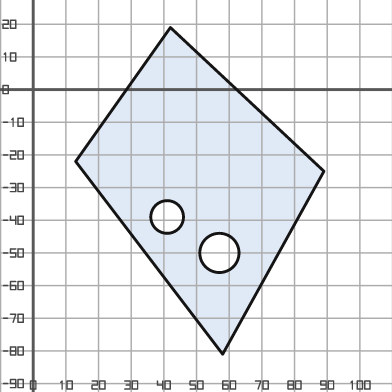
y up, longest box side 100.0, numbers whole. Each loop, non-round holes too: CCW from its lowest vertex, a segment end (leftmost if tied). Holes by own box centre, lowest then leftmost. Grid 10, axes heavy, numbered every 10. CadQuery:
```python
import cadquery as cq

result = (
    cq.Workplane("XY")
    .moveTo(58.0, -81.0)
    .lineTo(89.0, -25.0)
    .lineTo(42.0, 19.0)
    .lineTo(13.0, -22.0)
    .close()
    .moveTo(57.0, -50.0)
    .circle(6.0)
    .moveTo(41.0, -39.0)
    .circle(5.0)
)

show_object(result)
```